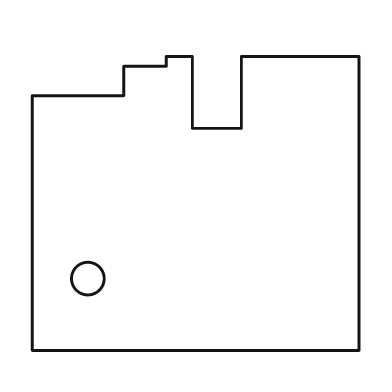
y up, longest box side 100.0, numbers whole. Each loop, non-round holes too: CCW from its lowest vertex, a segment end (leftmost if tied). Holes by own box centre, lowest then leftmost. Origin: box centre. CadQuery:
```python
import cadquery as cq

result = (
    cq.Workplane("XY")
    .moveTo(-50.0, -45.0)
    .lineTo(50.0, -45.0)
    .lineTo(50.0, 45.0)
    .lineTo(14.0, 45.0)
    .lineTo(14.0, 23.0)
    .lineTo(-1.0, 23.0)
    .lineTo(-1.0, 45.0)
    .lineTo(-9.0, 45.0)
    .lineTo(-9.0, 42.0)
    .lineTo(-22.0, 42.0)
    .lineTo(-22.0, 33.0)
    .lineTo(-50.0, 33.0)
    .close()
    .moveTo(-33.0, -23.0)
    .circle(5.0)
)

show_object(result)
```